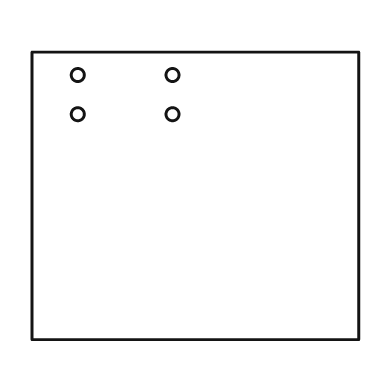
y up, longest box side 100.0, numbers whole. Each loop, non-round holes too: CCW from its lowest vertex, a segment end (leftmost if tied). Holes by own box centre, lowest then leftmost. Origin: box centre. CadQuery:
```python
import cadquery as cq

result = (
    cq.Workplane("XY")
    .moveTo(-50.0, -44.0)
    .lineTo(50.0, -44.0)
    .lineTo(50.0, 44.0)
    .lineTo(-50.0, 44.0)
    .close()
    .moveTo(-36.0, 25.0)
    .circle(2.0)
    .moveTo(-7.0, 25.0)
    .circle(2.0)
    .moveTo(-36.0, 37.0)
    .circle(2.0)
    .moveTo(-7.0, 37.0)
    .circle(2.0)
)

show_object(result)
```